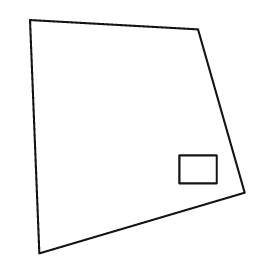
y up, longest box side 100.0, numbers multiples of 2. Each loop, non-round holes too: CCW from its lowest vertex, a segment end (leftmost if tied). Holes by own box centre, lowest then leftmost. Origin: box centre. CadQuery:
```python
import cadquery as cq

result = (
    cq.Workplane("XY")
    .moveTo(-42.0, -50.0)
    .lineTo(46.0, -24.0)
    .lineTo(26.0, 46.0)
    .lineTo(-46.0, 50.0)
    .close()
    .moveTo(18.0, -20.0)
    .lineTo(34.0, -20.0)
    .lineTo(34.0, -8.0)
    .lineTo(18.0, -8.0)
    .close()
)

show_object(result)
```